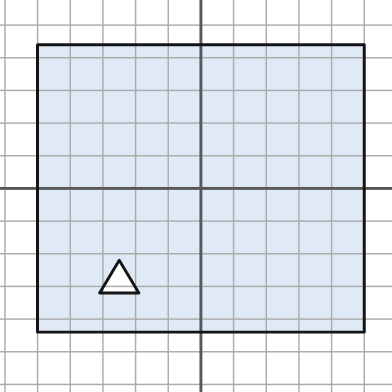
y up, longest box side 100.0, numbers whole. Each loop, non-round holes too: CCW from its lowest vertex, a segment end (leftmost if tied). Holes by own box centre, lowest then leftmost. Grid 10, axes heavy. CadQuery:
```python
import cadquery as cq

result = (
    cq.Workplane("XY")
    .moveTo(-50.0, -44.0)
    .lineTo(50.0, -44.0)
    .lineTo(50.0, 44.0)
    .lineTo(-50.0, 44.0)
    .close()
    .moveTo(-31.0, -32.0)
    .lineTo(-19.0, -32.0)
    .lineTo(-25.0, -22.0)
    .close()
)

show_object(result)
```